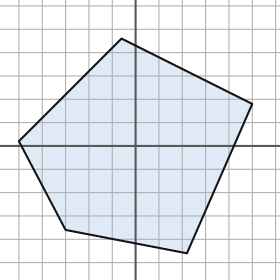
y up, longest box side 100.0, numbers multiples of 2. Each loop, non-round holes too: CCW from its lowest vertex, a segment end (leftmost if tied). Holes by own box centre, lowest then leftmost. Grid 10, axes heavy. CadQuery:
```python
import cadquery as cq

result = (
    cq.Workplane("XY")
    .moveTo(22.0, -46.0)
    .lineTo(50.0, 18.0)
    .lineTo(-6.0, 46.0)
    .lineTo(-50.0, 2.0)
    .lineTo(-30.0, -36.0)
    .close()
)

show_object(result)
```